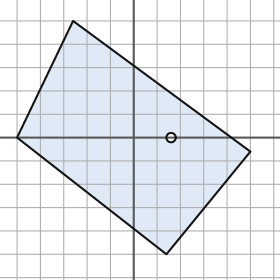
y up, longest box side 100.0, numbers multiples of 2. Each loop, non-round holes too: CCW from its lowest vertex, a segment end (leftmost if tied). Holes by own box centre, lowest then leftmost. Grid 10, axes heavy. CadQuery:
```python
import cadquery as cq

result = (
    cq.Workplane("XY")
    .moveTo(14.0, -50.0)
    .lineTo(50.0, -6.0)
    .lineTo(-26.0, 50.0)
    .lineTo(-50.0, 0.0)
    .close()
    .moveTo(16.0, 0.0)
    .circle(2.0)
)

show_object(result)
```